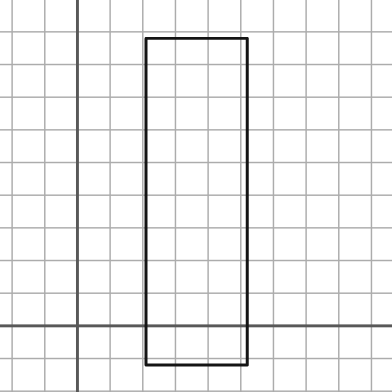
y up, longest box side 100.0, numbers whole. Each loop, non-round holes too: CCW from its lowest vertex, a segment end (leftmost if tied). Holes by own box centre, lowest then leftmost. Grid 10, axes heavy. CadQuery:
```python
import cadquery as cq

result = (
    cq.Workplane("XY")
    .moveTo(21.0, -12.0)
    .lineTo(52.0, -12.0)
    .lineTo(52.0, 88.0)
    .lineTo(21.0, 88.0)
    .close()
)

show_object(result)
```